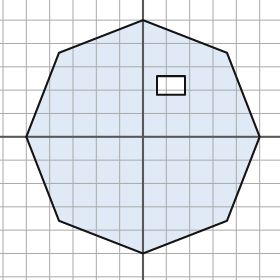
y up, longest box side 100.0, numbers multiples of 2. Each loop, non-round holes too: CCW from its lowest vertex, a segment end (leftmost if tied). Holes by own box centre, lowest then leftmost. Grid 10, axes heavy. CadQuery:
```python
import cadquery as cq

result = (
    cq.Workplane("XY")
    .moveTo(0.0, -50.0)
    .lineTo(36.0, -36.0)
    .lineTo(50.0, 0.0)
    .lineTo(36.0, 36.0)
    .lineTo(0.0, 50.0)
    .lineTo(-36.0, 36.0)
    .lineTo(-50.0, 0.0)
    .lineTo(-36.0, -36.0)
    .close()
    .moveTo(6.0, 18.0)
    .lineTo(18.0, 18.0)
    .lineTo(18.0, 26.0)
    .lineTo(6.0, 26.0)
    .close()
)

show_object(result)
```